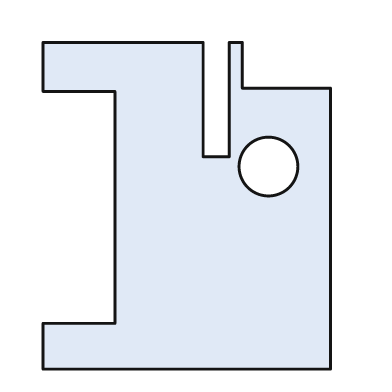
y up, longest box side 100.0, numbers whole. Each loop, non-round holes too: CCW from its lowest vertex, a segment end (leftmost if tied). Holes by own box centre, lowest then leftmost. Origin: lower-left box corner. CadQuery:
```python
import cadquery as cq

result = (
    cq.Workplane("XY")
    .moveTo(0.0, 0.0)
    .lineTo(88.0, 0.0)
    .lineTo(88.0, 86.0)
    .lineTo(61.0, 86.0)
    .lineTo(61.0, 100.0)
    .lineTo(57.0, 100.0)
    .lineTo(57.0, 65.0)
    .lineTo(49.0, 65.0)
    .lineTo(49.0, 100.0)
    .lineTo(0.0, 100.0)
    .lineTo(0.0, 85.0)
    .lineTo(22.0, 85.0)
    .lineTo(22.0, 14.0)
    .lineTo(0.0, 14.0)
    .close()
    .moveTo(69.0, 62.0)
    .circle(9.0)
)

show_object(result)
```